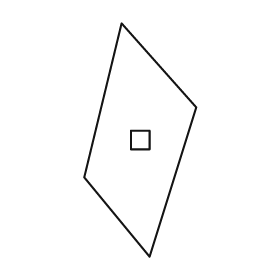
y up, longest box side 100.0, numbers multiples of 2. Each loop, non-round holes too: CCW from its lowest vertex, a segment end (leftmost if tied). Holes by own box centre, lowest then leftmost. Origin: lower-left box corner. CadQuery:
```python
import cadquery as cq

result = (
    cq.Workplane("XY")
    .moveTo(28.0, 0.0)
    .lineTo(48.0, 64.0)
    .lineTo(16.0, 100.0)
    .lineTo(0.0, 34.0)
    .close()
    .moveTo(20.0, 46.0)
    .lineTo(28.0, 46.0)
    .lineTo(28.0, 54.0)
    .lineTo(20.0, 54.0)
    .close()
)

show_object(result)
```